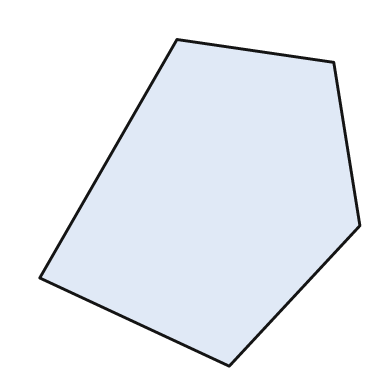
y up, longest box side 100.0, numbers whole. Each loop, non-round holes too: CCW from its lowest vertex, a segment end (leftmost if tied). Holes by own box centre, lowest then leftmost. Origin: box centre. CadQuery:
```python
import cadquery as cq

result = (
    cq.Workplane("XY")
    .moveTo(9.0, -50.0)
    .lineTo(49.0, -7.0)
    .lineTo(41.0, 43.0)
    .lineTo(-7.0, 50.0)
    .lineTo(-49.0, -23.0)
    .close()
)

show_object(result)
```